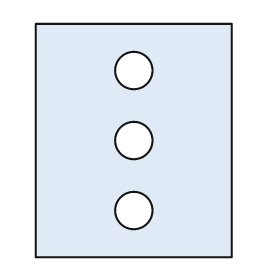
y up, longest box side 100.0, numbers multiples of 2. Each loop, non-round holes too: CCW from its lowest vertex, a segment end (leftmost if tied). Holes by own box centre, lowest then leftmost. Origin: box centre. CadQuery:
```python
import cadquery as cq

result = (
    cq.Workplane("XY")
    .moveTo(-42.0, -50.0)
    .lineTo(42.0, -50.0)
    .lineTo(42.0, 50.0)
    .lineTo(-42.0, 50.0)
    .close()
    .moveTo(0.0, -30.0)
    .circle(8.0)
    .moveTo(0.0, 0.0)
    .circle(8.0)
    .moveTo(0.0, 30.0)
    .circle(8.0)
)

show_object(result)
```